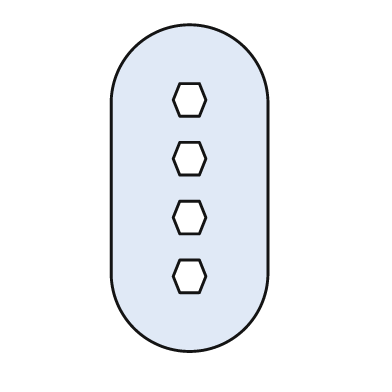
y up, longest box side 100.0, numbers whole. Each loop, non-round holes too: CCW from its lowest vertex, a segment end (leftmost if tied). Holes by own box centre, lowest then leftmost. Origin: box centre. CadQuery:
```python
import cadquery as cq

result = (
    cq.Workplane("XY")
    .moveTo(-24.0, -26.0)
    .threePointArc((0.0, -50.0), (24.0, -26.0))
    .lineTo(24.0, 26.0)
    .threePointArc((0.0, 50.0), (-24.0, 26.0))
    .close()
    .moveTo(-3.0, -32.0)
    .lineTo(3.0, -32.0)
    .lineTo(5.0, -27.0)
    .lineTo(3.0, -22.0)
    .lineTo(-3.0, -22.0)
    .lineTo(-5.0, -27.0)
    .close()
    .moveTo(-3.0, -14.0)
    .lineTo(3.0, -14.0)
    .lineTo(5.0, -9.0)
    .lineTo(3.0, -4.0)
    .lineTo(-3.0, -4.0)
    .lineTo(-5.0, -9.0)
    .close()
    .moveTo(-3.0, 4.0)
    .lineTo(3.0, 4.0)
    .lineTo(5.0, 9.0)
    .lineTo(3.0, 14.0)
    .lineTo(-3.0, 14.0)
    .lineTo(-5.0, 9.0)
    .close()
    .moveTo(-3.0, 22.0)
    .lineTo(3.0, 22.0)
    .lineTo(5.0, 27.0)
    .lineTo(3.0, 32.0)
    .lineTo(-3.0, 32.0)
    .lineTo(-5.0, 27.0)
    .close()
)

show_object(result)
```